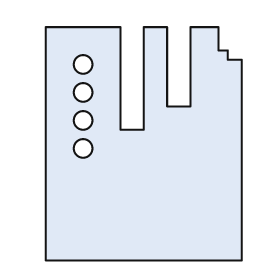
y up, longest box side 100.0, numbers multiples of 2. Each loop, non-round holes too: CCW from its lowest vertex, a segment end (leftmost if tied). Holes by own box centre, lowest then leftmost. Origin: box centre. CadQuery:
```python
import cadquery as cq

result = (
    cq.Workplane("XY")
    .moveTo(-42.0, -50.0)
    .lineTo(42.0, -50.0)
    .lineTo(42.0, 36.0)
    .lineTo(36.0, 36.0)
    .lineTo(36.0, 40.0)
    .lineTo(32.0, 40.0)
    .lineTo(32.0, 50.0)
    .lineTo(20.0, 50.0)
    .lineTo(20.0, 16.0)
    .lineTo(10.0, 16.0)
    .lineTo(10.0, 50.0)
    .lineTo(0.0, 50.0)
    .lineTo(0.0, 6.0)
    .lineTo(-10.0, 6.0)
    .lineTo(-10.0, 50.0)
    .lineTo(-42.0, 50.0)
    .close()
    .moveTo(-26.0, -2.0)
    .circle(4.0)
    .moveTo(-26.0, 10.0)
    .circle(4.0)
    .moveTo(-26.0, 22.0)
    .circle(4.0)
    .moveTo(-26.0, 34.0)
    .circle(4.0)
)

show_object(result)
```